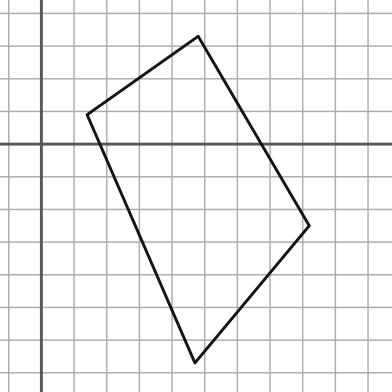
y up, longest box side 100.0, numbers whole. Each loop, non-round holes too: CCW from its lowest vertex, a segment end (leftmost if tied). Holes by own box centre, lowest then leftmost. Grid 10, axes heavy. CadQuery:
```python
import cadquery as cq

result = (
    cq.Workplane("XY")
    .moveTo(47.0, -67.0)
    .lineTo(82.0, -25.0)
    .lineTo(48.0, 33.0)
    .lineTo(14.0, 9.0)
    .close()
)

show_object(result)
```